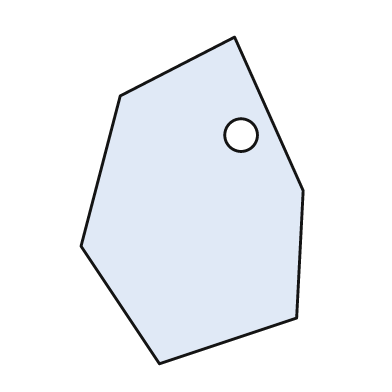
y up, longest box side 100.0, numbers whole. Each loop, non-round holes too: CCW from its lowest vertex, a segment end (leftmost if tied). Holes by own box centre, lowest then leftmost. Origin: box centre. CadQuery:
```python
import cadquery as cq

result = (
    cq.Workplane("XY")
    .moveTo(-10.0, -50.0)
    .lineTo(32.0, -36.0)
    .lineTo(34.0, 3.0)
    .lineTo(13.0, 50.0)
    .lineTo(-22.0, 32.0)
    .lineTo(-34.0, -14.0)
    .close()
    .moveTo(15.0, 20.0)
    .circle(5.0)
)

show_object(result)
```